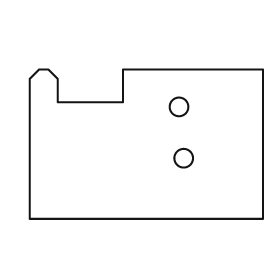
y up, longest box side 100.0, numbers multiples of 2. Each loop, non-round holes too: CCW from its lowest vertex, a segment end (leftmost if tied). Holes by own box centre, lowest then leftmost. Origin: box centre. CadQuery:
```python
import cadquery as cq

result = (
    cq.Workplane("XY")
    .moveTo(-50.0, -32.0)
    .lineTo(50.0, -32.0)
    .lineTo(50.0, 32.0)
    .lineTo(-10.0, 32.0)
    .lineTo(-10.0, 18.0)
    .lineTo(-38.0, 18.0)
    .lineTo(-38.0, 28.0)
    .lineTo(-42.0, 32.0)
    .lineTo(-46.0, 32.0)
    .lineTo(-50.0, 28.0)
    .close()
    .moveTo(16.0, -6.0)
    .circle(4.0)
    .moveTo(14.0, 16.0)
    .circle(4.0)
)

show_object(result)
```